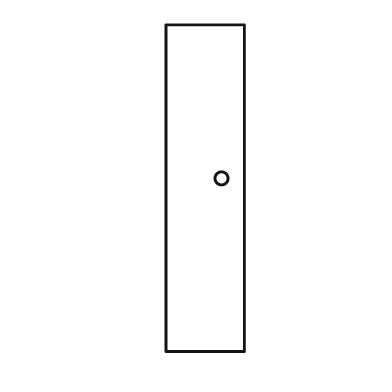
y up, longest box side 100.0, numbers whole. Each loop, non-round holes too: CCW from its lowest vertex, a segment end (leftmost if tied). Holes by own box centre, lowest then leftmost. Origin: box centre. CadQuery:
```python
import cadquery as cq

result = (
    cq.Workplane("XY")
    .moveTo(-12.0, -50.0)
    .lineTo(12.0, -50.0)
    .lineTo(12.0, 50.0)
    .lineTo(-12.0, 50.0)
    .close()
    .moveTo(5.0, 3.0)
    .circle(2.0)
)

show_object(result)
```